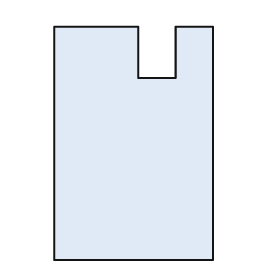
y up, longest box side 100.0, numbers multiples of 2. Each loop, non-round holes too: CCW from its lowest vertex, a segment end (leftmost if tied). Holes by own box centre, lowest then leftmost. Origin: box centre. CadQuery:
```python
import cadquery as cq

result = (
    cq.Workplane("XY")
    .moveTo(-34.0, -50.0)
    .lineTo(34.0, -50.0)
    .lineTo(34.0, 50.0)
    .lineTo(18.0, 50.0)
    .lineTo(18.0, 28.0)
    .lineTo(2.0, 28.0)
    .lineTo(2.0, 50.0)
    .lineTo(-34.0, 50.0)
    .close()
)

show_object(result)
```